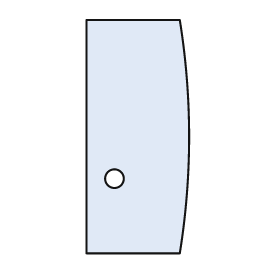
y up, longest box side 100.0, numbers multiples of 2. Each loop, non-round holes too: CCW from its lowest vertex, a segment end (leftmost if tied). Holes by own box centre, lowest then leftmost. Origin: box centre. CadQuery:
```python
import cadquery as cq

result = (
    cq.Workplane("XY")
    .moveTo(-22.0, -50.0)
    .lineTo(18.0, -50.0)
    .threePointArc((22.0, 0.0), (18.0, 50.0))
    .lineTo(-22.0, 50.0)
    .close()
    .moveTo(-10.0, -18.0)
    .circle(4.0)
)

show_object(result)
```